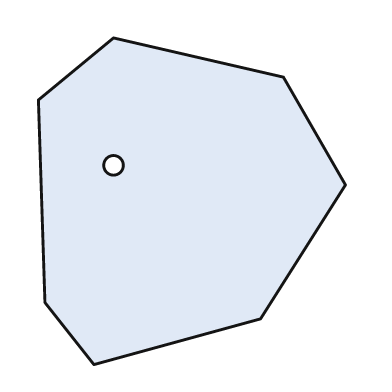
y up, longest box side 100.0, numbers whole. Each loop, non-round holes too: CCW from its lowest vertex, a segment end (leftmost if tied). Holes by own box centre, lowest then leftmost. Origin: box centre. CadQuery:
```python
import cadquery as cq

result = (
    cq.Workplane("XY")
    .moveTo(-30.0, -50.0)
    .lineTo(21.0, -36.0)
    .lineTo(47.0, 5.0)
    .lineTo(28.0, 38.0)
    .lineTo(-24.0, 50.0)
    .lineTo(-47.0, 31.0)
    .lineTo(-45.0, -31.0)
    .close()
    .moveTo(-24.0, 11.0)
    .circle(3.0)
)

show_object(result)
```